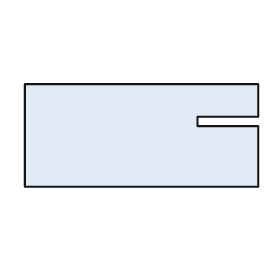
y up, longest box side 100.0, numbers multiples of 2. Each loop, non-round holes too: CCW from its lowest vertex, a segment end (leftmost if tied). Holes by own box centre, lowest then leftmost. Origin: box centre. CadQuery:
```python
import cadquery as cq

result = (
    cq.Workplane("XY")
    .moveTo(-50.0, -22.0)
    .lineTo(50.0, -22.0)
    .lineTo(50.0, 4.0)
    .lineTo(24.0, 4.0)
    .lineTo(24.0, 8.0)
    .lineTo(50.0, 8.0)
    .lineTo(50.0, 22.0)
    .lineTo(-50.0, 22.0)
    .close()
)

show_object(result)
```